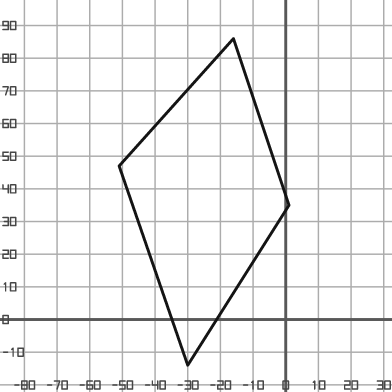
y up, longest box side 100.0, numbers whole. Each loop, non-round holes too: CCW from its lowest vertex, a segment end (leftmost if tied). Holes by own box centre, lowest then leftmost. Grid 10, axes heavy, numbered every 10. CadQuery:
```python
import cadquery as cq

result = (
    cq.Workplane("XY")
    .moveTo(-30.0, -14.0)
    .lineTo(1.0, 35.0)
    .lineTo(-16.0, 86.0)
    .lineTo(-51.0, 47.0)
    .close()
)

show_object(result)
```